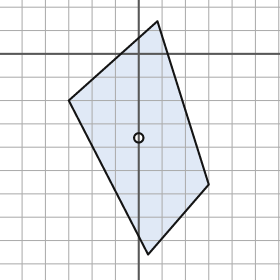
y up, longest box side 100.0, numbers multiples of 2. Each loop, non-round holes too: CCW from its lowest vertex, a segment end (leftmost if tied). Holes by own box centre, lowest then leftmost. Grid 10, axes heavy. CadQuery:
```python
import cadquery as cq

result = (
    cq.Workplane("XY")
    .moveTo(4.0, -86.0)
    .lineTo(30.0, -56.0)
    .lineTo(8.0, 14.0)
    .lineTo(-30.0, -20.0)
    .close()
    .moveTo(0.0, -36.0)
    .circle(2.0)
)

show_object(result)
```